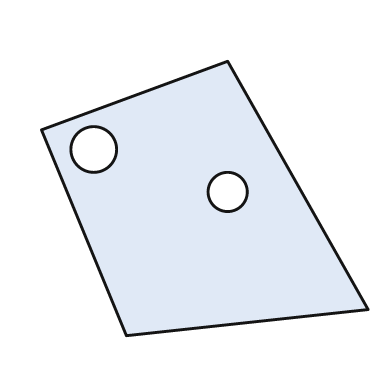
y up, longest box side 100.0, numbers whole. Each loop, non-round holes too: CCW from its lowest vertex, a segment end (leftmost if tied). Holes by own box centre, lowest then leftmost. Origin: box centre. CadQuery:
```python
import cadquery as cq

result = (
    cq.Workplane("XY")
    .moveTo(-24.0, -42.0)
    .lineTo(50.0, -34.0)
    .lineTo(7.0, 42.0)
    .lineTo(-50.0, 21.0)
    .close()
    .moveTo(7.0, 2.0)
    .circle(6.0)
    .moveTo(-34.0, 15.0)
    .circle(7.0)
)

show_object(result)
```